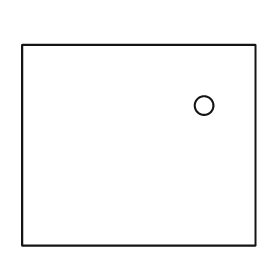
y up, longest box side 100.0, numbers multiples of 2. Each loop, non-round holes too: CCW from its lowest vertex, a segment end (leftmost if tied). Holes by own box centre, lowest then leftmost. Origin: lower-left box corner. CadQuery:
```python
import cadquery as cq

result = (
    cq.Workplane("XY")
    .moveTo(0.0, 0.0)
    .lineTo(100.0, 0.0)
    .lineTo(100.0, 86.0)
    .lineTo(0.0, 86.0)
    .close()
    .moveTo(78.0, 60.0)
    .circle(4.0)
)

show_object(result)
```